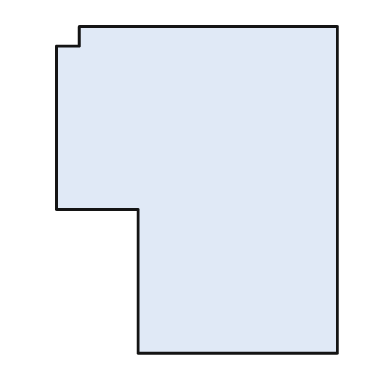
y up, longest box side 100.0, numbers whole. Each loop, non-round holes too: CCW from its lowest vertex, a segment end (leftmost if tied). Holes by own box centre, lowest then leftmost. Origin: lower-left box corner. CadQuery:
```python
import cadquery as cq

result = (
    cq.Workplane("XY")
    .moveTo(25.0, 0.0)
    .lineTo(86.0, 0.0)
    .lineTo(86.0, 100.0)
    .lineTo(7.0, 100.0)
    .lineTo(7.0, 94.0)
    .lineTo(0.0, 94.0)
    .lineTo(0.0, 44.0)
    .lineTo(25.0, 44.0)
    .close()
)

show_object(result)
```